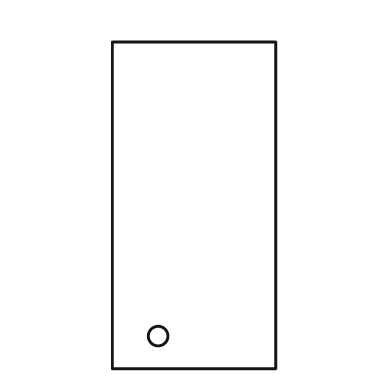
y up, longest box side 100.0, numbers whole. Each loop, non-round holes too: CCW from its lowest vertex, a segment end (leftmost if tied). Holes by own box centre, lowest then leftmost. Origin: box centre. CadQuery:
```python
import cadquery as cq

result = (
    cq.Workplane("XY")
    .moveTo(-25.0, -50.0)
    .lineTo(25.0, -50.0)
    .lineTo(25.0, 50.0)
    .lineTo(-25.0, 50.0)
    .close()
    .moveTo(-11.0, -40.0)
    .circle(3.0)
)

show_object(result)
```